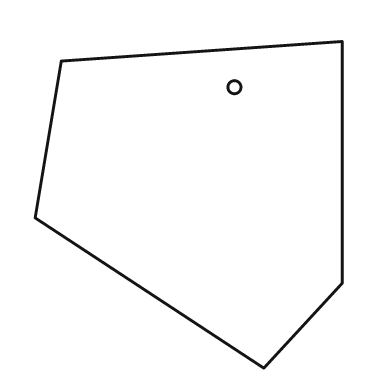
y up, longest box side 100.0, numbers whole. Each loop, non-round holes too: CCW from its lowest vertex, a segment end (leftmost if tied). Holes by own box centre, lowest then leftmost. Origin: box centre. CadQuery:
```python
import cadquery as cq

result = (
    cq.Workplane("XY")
    .moveTo(23.0, -50.0)
    .lineTo(47.0, -24.0)
    .lineTo(47.0, 50.0)
    .lineTo(-39.0, 44.0)
    .lineTo(-47.0, -4.0)
    .close()
    .moveTo(14.0, 36.0)
    .circle(2.0)
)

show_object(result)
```